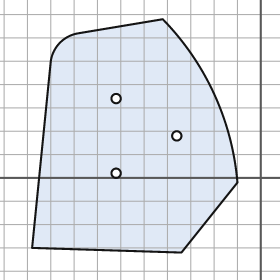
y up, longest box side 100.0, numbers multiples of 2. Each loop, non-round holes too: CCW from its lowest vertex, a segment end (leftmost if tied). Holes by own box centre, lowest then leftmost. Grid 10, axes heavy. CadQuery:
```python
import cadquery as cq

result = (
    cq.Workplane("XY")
    .moveTo(-34.0, -32.0)
    .lineTo(-10.0, -2.0)
    .threePointArc((-20.0, 36.0), (-42.0, 68.0))
    .lineTo(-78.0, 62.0)
    .threePointArc((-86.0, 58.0), (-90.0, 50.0))
    .lineTo(-98.0, -30.0)
    .close()
    .moveTo(-62.0, 2.0)
    .circle(2.0)
    .moveTo(-36.0, 18.0)
    .circle(2.0)
    .moveTo(-62.0, 34.0)
    .circle(2.0)
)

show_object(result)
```